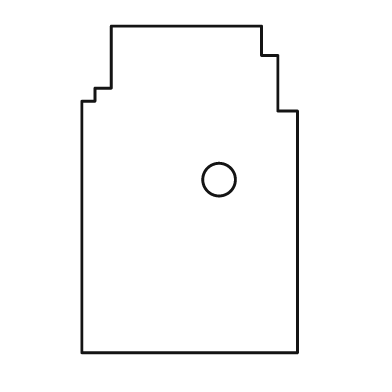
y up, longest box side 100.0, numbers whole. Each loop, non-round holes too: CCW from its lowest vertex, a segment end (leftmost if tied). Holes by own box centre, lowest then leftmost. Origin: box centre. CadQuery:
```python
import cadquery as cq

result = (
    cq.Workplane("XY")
    .moveTo(-33.0, -50.0)
    .lineTo(33.0, -50.0)
    .lineTo(33.0, 24.0)
    .lineTo(27.0, 24.0)
    .lineTo(27.0, 41.0)
    .lineTo(22.0, 41.0)
    .lineTo(22.0, 50.0)
    .lineTo(-24.0, 50.0)
    .lineTo(-24.0, 31.0)
    .lineTo(-29.0, 31.0)
    .lineTo(-29.0, 27.0)
    .lineTo(-33.0, 27.0)
    .close()
    .moveTo(9.0, 3.0)
    .circle(5.0)
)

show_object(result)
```